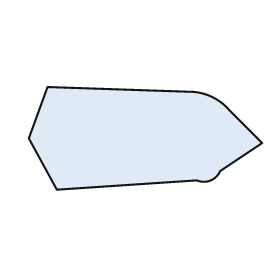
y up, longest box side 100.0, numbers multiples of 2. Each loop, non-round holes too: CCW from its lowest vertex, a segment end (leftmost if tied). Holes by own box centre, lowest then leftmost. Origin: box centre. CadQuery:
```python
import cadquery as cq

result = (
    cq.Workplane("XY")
    .moveTo(-38.0, -22.0)
    .lineTo(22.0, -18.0)
    .threePointArc((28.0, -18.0), (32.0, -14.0))
    .lineTo(50.0, -2.0)
    .lineTo(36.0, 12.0)
    .threePointArc((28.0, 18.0), (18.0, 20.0))
    .lineTo(-42.0, 22.0)
    .lineTo(-50.0, 0.0)
    .close()
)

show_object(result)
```